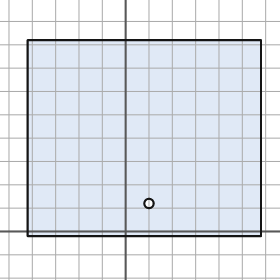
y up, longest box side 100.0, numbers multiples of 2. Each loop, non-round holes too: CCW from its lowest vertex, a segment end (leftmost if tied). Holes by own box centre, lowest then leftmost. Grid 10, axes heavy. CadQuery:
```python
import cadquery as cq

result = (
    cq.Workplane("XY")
    .moveTo(-42.0, -2.0)
    .lineTo(58.0, -2.0)
    .lineTo(58.0, 82.0)
    .lineTo(-42.0, 82.0)
    .close()
    .moveTo(10.0, 12.0)
    .circle(2.0)
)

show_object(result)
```